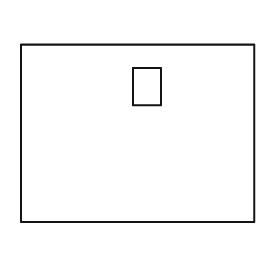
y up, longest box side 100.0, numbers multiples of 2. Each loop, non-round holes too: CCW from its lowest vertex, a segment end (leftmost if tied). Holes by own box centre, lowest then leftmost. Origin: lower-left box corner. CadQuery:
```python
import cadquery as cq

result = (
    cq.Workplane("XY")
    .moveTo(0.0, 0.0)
    .lineTo(100.0, 0.0)
    .lineTo(100.0, 76.0)
    .lineTo(0.0, 76.0)
    .close()
    .moveTo(48.0, 50.0)
    .lineTo(60.0, 50.0)
    .lineTo(60.0, 66.0)
    .lineTo(48.0, 66.0)
    .close()
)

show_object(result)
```